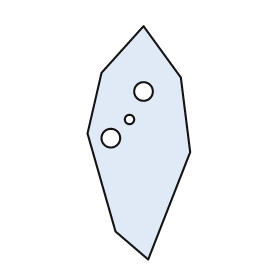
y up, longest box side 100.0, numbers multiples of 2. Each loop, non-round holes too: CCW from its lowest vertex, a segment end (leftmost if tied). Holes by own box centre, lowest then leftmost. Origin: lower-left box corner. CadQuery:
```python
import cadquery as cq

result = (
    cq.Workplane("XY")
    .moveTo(26.0, 0.0)
    .lineTo(44.0, 46.0)
    .lineTo(40.0, 78.0)
    .lineTo(24.0, 100.0)
    .lineTo(6.0, 80.0)
    .lineTo(0.0, 54.0)
    .lineTo(12.0, 12.0)
    .close()
    .moveTo(10.0, 52.0)
    .circle(4.0)
    .moveTo(18.0, 60.0)
    .circle(2.0)
    .moveTo(24.0, 72.0)
    .circle(4.0)
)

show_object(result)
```